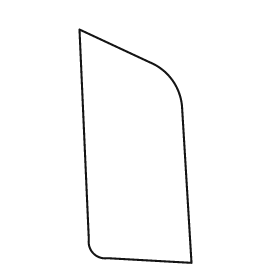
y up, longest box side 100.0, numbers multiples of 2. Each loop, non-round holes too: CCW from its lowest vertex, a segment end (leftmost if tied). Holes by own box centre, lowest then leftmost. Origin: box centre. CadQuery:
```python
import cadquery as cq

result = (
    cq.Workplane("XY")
    .moveTo(24.0, -50.0)
    .lineTo(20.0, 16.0)
    .threePointArc((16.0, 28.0), (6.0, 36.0))
    .lineTo(-24.0, 50.0)
    .lineTo(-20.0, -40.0)
    .threePointArc((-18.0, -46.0), (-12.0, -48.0))
    .close()
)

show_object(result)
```